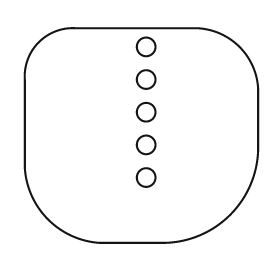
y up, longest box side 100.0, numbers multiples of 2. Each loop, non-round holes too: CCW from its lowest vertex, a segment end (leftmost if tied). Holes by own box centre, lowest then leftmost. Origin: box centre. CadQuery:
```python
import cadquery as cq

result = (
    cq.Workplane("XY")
    .moveTo(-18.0, -46.0)
    .lineTo(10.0, -46.0)
    .threePointArc((38.0, -34.0), (50.0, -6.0))
    .lineTo(50.0, 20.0)
    .threePointArc((42.0, 38.0), (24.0, 46.0))
    .lineTo(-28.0, 46.0)
    .threePointArc((-44.0, 40.0), (-50.0, 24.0))
    .lineTo(-50.0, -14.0)
    .threePointArc((-40.0, -36.0), (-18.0, -46.0))
    .close()
    .moveTo(2.0, -18.0)
    .circle(4.0)
    .moveTo(2.0, -4.0)
    .circle(4.0)
    .moveTo(2.0, 10.0)
    .circle(4.0)
    .moveTo(2.0, 24.0)
    .circle(4.0)
    .moveTo(2.0, 38.0)
    .circle(4.0)
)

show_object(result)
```